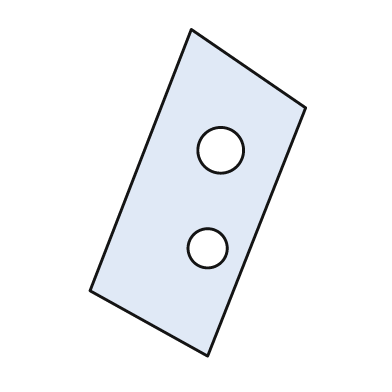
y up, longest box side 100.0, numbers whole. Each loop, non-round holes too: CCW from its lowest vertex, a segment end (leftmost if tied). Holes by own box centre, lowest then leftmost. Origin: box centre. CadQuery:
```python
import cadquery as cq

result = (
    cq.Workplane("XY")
    .moveTo(3.0, -50.0)
    .lineTo(33.0, 26.0)
    .lineTo(-2.0, 50.0)
    .lineTo(-33.0, -30.0)
    .close()
    .moveTo(3.0, -17.0)
    .circle(6.0)
    .moveTo(7.0, 13.0)
    .circle(7.0)
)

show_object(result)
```